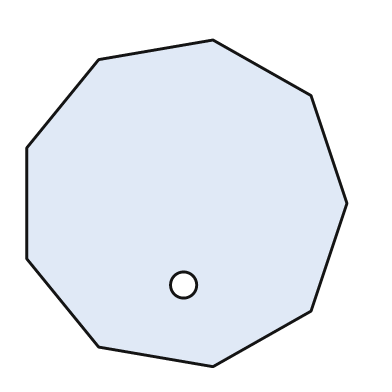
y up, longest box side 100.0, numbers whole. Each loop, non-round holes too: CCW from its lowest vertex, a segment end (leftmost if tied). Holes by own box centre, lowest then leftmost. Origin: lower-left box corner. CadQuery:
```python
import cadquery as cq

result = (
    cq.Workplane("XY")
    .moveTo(57.0, 0.0)
    .lineTo(87.0, 17.0)
    .lineTo(98.0, 50.0)
    .lineTo(87.0, 83.0)
    .lineTo(57.0, 100.0)
    .lineTo(22.0, 94.0)
    .lineTo(0.0, 67.0)
    .lineTo(0.0, 33.0)
    .lineTo(22.0, 6.0)
    .close()
    .moveTo(48.0, 25.0)
    .circle(4.0)
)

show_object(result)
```